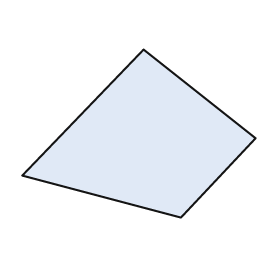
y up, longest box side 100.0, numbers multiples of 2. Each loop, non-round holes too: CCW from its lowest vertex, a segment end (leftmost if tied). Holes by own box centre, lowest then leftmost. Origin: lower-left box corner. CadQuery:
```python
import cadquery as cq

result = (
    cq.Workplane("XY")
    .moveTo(68.0, 0.0)
    .lineTo(100.0, 34.0)
    .lineTo(52.0, 72.0)
    .lineTo(0.0, 18.0)
    .close()
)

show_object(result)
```